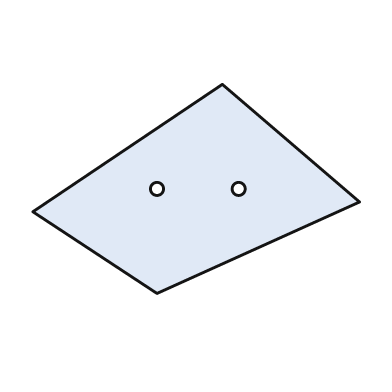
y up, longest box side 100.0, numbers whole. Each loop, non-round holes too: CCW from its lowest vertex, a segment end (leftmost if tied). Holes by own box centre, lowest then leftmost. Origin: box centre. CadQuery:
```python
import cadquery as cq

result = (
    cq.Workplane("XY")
    .moveTo(-12.0, -32.0)
    .lineTo(50.0, -4.0)
    .lineTo(8.0, 32.0)
    .lineTo(-50.0, -7.0)
    .close()
    .moveTo(-12.0, 0.0)
    .circle(2.0)
    .moveTo(13.0, 0.0)
    .circle(2.0)
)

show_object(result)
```